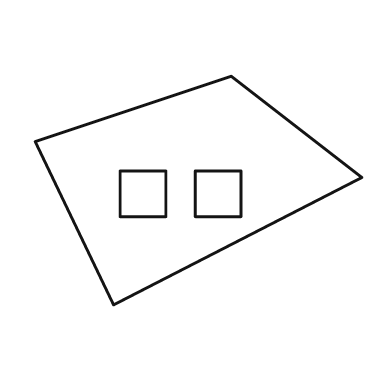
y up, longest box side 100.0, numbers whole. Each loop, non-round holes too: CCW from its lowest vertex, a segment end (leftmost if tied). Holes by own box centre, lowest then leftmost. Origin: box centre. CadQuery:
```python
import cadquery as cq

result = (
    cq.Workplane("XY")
    .moveTo(-26.0, -35.0)
    .lineTo(50.0, 4.0)
    .lineTo(10.0, 35.0)
    .lineTo(-50.0, 15.0)
    .close()
    .moveTo(-24.0, -8.0)
    .lineTo(-10.0, -8.0)
    .lineTo(-10.0, 6.0)
    .lineTo(-24.0, 6.0)
    .close()
    .moveTo(-1.0, -8.0)
    .lineTo(13.0, -8.0)
    .lineTo(13.0, 6.0)
    .lineTo(-1.0, 6.0)
    .close()
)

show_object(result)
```